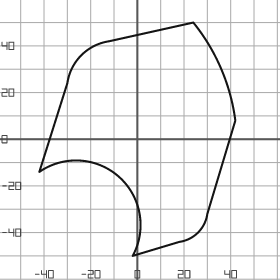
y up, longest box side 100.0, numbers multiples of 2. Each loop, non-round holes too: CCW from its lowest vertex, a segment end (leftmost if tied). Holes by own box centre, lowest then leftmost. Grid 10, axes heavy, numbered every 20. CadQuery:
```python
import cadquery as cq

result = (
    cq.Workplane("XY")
    .moveTo(-2.0, -50.0)
    .lineTo(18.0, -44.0)
    .threePointArc((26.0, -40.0), (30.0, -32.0))
    .lineTo(42.0, 8.0)
    .threePointArc((36.0, 30.0), (24.0, 50.0))
    .lineTo(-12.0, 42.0)
    .threePointArc((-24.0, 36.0), (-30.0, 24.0))
    .lineTo(-42.0, -14.0)
    .threePointArc((-8.0, -16.0), (-2.0, -50.0))
    .close()
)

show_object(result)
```